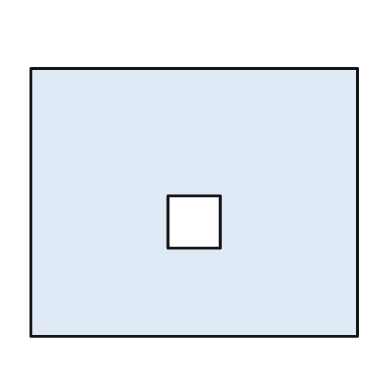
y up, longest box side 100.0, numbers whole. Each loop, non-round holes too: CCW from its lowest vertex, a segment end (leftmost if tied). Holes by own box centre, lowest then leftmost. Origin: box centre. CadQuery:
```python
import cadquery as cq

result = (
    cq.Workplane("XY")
    .moveTo(-50.0, -41.0)
    .lineTo(50.0, -41.0)
    .lineTo(50.0, 41.0)
    .lineTo(-50.0, 41.0)
    .close()
    .moveTo(-8.0, -14.0)
    .lineTo(8.0, -14.0)
    .lineTo(8.0, 2.0)
    .lineTo(-8.0, 2.0)
    .close()
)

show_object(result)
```